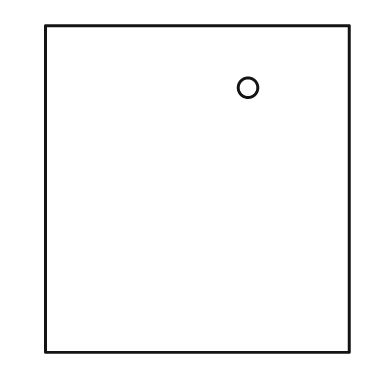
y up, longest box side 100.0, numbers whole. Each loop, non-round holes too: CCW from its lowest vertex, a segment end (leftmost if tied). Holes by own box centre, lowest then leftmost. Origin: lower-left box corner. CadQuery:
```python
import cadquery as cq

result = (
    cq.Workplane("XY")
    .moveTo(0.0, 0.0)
    .lineTo(93.0, 0.0)
    .lineTo(93.0, 100.0)
    .lineTo(0.0, 100.0)
    .close()
    .moveTo(62.0, 81.0)
    .circle(3.0)
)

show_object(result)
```